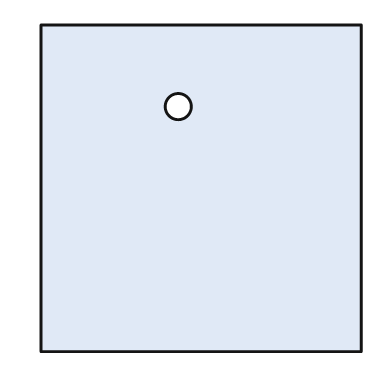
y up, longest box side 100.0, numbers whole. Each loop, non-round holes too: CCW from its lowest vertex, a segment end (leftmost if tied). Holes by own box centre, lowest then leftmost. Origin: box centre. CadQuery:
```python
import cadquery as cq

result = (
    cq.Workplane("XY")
    .moveTo(-49.0, -50.0)
    .lineTo(49.0, -50.0)
    .lineTo(49.0, 50.0)
    .lineTo(-49.0, 50.0)
    .close()
    .moveTo(-7.0, 25.0)
    .circle(4.0)
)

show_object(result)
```